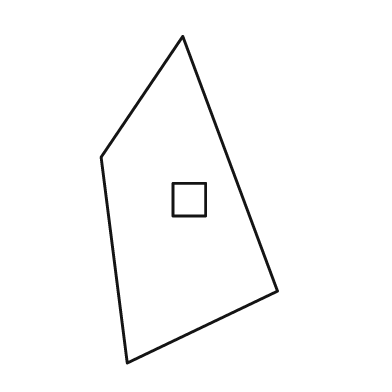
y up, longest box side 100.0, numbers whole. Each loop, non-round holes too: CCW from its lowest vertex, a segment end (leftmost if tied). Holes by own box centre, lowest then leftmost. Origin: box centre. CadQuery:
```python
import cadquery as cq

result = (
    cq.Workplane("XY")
    .moveTo(-19.0, -50.0)
    .lineTo(27.0, -28.0)
    .lineTo(-2.0, 50.0)
    .lineTo(-27.0, 13.0)
    .close()
    .moveTo(-5.0, -5.0)
    .lineTo(5.0, -5.0)
    .lineTo(5.0, 5.0)
    .lineTo(-5.0, 5.0)
    .close()
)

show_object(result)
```